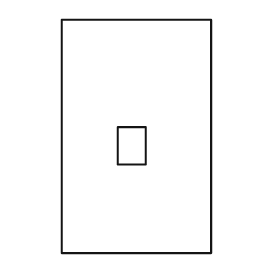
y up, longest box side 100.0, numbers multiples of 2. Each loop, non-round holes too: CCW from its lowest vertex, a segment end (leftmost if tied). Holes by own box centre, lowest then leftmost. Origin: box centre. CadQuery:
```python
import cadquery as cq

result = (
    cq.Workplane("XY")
    .moveTo(-32.0, -50.0)
    .lineTo(32.0, -50.0)
    .lineTo(32.0, 50.0)
    .lineTo(-32.0, 50.0)
    .close()
    .moveTo(-8.0, -12.0)
    .lineTo(4.0, -12.0)
    .lineTo(4.0, 4.0)
    .lineTo(-8.0, 4.0)
    .close()
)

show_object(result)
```